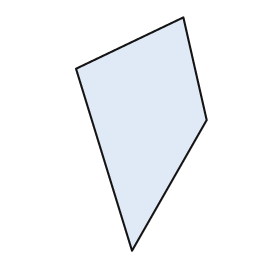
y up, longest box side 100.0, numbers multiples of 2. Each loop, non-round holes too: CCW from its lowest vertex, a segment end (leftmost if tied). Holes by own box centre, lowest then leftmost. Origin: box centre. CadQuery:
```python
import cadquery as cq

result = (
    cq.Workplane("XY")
    .moveTo(-4.0, -50.0)
    .lineTo(28.0, 6.0)
    .lineTo(18.0, 50.0)
    .lineTo(-28.0, 28.0)
    .close()
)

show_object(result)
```